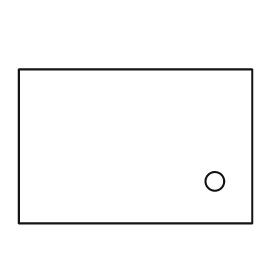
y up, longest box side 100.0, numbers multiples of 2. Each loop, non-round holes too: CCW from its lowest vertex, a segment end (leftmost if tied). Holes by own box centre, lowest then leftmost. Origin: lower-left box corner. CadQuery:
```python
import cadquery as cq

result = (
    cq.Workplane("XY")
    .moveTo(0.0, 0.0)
    .lineTo(100.0, 0.0)
    .lineTo(100.0, 66.0)
    .lineTo(0.0, 66.0)
    .close()
    .moveTo(84.0, 18.0)
    .circle(4.0)
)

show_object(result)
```